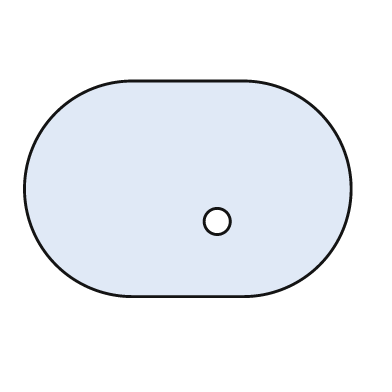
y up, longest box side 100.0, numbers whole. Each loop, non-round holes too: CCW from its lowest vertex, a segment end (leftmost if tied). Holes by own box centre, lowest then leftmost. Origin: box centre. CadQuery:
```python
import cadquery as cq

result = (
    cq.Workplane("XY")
    .moveTo(-17.0, -33.0)
    .lineTo(17.0, -33.0)
    .threePointArc((50.0, 0.0), (17.0, 33.0))
    .lineTo(-17.0, 33.0)
    .threePointArc((-50.0, 0.0), (-17.0, -33.0))
    .close()
    .moveTo(9.0, -10.0)
    .circle(4.0)
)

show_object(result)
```